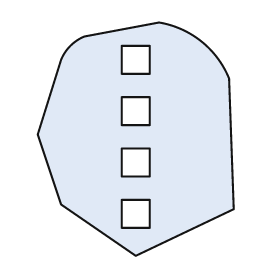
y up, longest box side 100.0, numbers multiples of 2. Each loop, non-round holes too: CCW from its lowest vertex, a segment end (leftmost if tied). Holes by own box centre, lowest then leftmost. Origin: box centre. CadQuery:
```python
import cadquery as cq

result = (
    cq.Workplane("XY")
    .moveTo(0.0, -50.0)
    .lineTo(42.0, -30.0)
    .lineTo(40.0, 26.0)
    .threePointArc((28.0, 42.0), (10.0, 50.0))
    .lineTo(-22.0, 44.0)
    .threePointArc((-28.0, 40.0), (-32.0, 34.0))
    .lineTo(-42.0, 2.0)
    .lineTo(-32.0, -28.0)
    .close()
    .moveTo(-6.0, -38.0)
    .lineTo(6.0, -38.0)
    .lineTo(6.0, -26.0)
    .lineTo(-6.0, -26.0)
    .close()
    .moveTo(-6.0, -16.0)
    .lineTo(6.0, -16.0)
    .lineTo(6.0, -4.0)
    .lineTo(-6.0, -4.0)
    .close()
    .moveTo(-6.0, 6.0)
    .lineTo(6.0, 6.0)
    .lineTo(6.0, 18.0)
    .lineTo(-6.0, 18.0)
    .close()
    .moveTo(-6.0, 28.0)
    .lineTo(6.0, 28.0)
    .lineTo(6.0, 40.0)
    .lineTo(-6.0, 40.0)
    .close()
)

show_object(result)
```